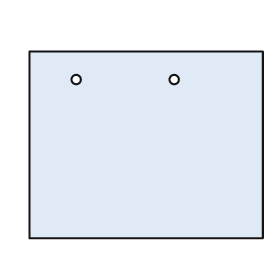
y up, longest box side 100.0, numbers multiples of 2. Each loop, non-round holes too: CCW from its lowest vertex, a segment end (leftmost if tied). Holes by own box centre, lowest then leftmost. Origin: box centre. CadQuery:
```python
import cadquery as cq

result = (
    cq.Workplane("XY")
    .moveTo(-50.0, -40.0)
    .lineTo(50.0, -40.0)
    .lineTo(50.0, 40.0)
    .lineTo(-50.0, 40.0)
    .close()
    .moveTo(-30.0, 28.0)
    .circle(2.0)
    .moveTo(12.0, 28.0)
    .circle(2.0)
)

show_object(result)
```